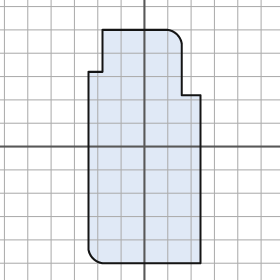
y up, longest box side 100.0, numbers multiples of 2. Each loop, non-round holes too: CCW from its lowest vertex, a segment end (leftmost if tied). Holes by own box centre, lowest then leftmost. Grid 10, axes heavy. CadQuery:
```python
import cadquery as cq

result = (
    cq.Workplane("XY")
    .moveTo(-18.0, -50.0)
    .lineTo(24.0, -50.0)
    .lineTo(24.0, 22.0)
    .lineTo(16.0, 22.0)
    .lineTo(16.0, 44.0)
    .threePointArc((14.0, 48.0), (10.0, 50.0))
    .lineTo(-18.0, 50.0)
    .lineTo(-18.0, 32.0)
    .lineTo(-24.0, 32.0)
    .lineTo(-24.0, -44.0)
    .threePointArc((-22.0, -48.0), (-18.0, -50.0))
    .close()
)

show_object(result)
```